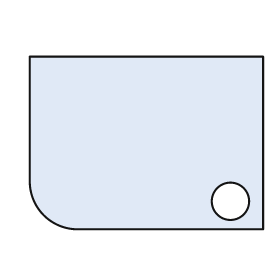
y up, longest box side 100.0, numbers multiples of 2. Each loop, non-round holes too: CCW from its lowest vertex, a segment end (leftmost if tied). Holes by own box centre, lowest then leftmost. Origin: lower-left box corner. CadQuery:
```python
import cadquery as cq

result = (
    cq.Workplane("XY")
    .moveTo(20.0, 0.0)
    .lineTo(100.0, 0.0)
    .lineTo(100.0, 74.0)
    .lineTo(0.0, 74.0)
    .lineTo(0.0, 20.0)
    .threePointArc((6.0, 6.0), (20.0, 0.0))
    .close()
    .moveTo(86.0, 12.0)
    .circle(8.0)
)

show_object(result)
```